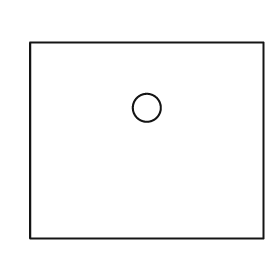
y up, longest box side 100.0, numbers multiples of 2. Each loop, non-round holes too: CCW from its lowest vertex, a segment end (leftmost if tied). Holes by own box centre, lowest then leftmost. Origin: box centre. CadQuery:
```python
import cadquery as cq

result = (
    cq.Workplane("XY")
    .moveTo(-50.0, -42.0)
    .lineTo(50.0, -42.0)
    .lineTo(50.0, 42.0)
    .lineTo(-50.0, 42.0)
    .close()
    .moveTo(0.0, 14.0)
    .circle(6.0)
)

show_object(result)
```